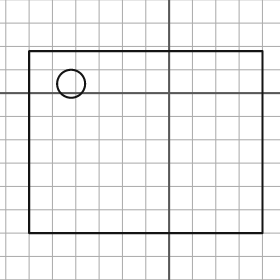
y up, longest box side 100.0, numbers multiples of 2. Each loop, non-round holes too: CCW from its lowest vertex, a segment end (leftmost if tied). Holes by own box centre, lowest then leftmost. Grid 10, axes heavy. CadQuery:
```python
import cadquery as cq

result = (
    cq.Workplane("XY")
    .moveTo(-60.0, -60.0)
    .lineTo(40.0, -60.0)
    .lineTo(40.0, 18.0)
    .lineTo(-60.0, 18.0)
    .close()
    .moveTo(-42.0, 4.0)
    .circle(6.0)
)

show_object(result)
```